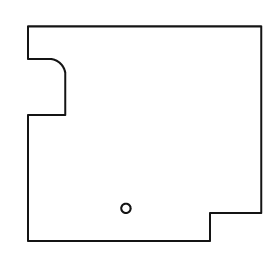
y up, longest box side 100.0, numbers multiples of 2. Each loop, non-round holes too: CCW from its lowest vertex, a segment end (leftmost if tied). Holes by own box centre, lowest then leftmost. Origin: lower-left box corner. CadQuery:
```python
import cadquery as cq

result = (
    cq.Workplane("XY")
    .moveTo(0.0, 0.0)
    .lineTo(78.0, 0.0)
    .lineTo(78.0, 12.0)
    .lineTo(100.0, 12.0)
    .lineTo(100.0, 92.0)
    .lineTo(0.0, 92.0)
    .lineTo(0.0, 78.0)
    .lineTo(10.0, 78.0)
    .threePointArc((14.0, 76.0), (16.0, 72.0))
    .lineTo(16.0, 54.0)
    .lineTo(0.0, 54.0)
    .close()
    .moveTo(42.0, 14.0)
    .circle(2.0)
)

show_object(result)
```